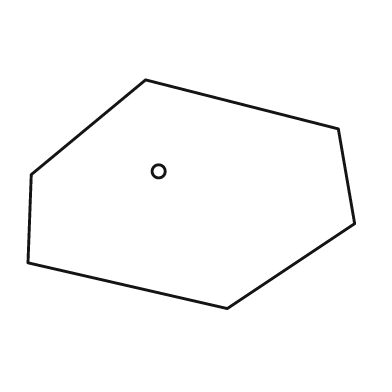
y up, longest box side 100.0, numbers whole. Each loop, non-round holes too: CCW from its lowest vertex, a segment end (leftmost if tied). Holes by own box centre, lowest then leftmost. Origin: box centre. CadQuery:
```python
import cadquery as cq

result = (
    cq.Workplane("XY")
    .moveTo(11.0, -35.0)
    .lineTo(50.0, -9.0)
    .lineTo(45.0, 20.0)
    .lineTo(-14.0, 35.0)
    .lineTo(-49.0, 6.0)
    .lineTo(-50.0, -21.0)
    .close()
    .moveTo(-10.0, 7.0)
    .circle(2.0)
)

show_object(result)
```